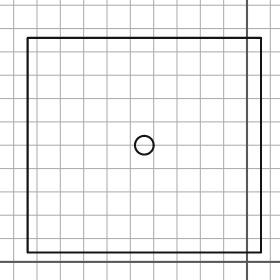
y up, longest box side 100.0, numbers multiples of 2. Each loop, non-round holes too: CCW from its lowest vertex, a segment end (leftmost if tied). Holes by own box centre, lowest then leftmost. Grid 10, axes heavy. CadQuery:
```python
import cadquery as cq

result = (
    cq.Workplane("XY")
    .moveTo(-94.0, 4.0)
    .lineTo(6.0, 4.0)
    .lineTo(6.0, 96.0)
    .lineTo(-94.0, 96.0)
    .close()
    .moveTo(-44.0, 50.0)
    .circle(4.0)
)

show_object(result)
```